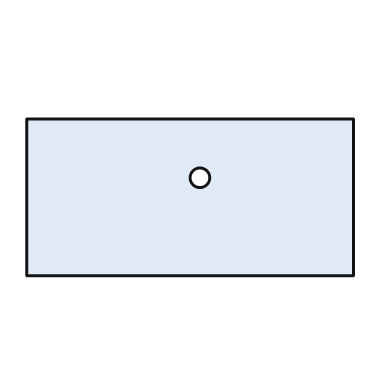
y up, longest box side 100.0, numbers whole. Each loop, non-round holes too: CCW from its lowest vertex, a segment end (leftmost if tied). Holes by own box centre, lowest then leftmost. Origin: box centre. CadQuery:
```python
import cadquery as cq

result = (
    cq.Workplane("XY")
    .moveTo(-50.0, -24.0)
    .lineTo(50.0, -24.0)
    .lineTo(50.0, 24.0)
    .lineTo(-50.0, 24.0)
    .close()
    .moveTo(3.0, 6.0)
    .circle(3.0)
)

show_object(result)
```